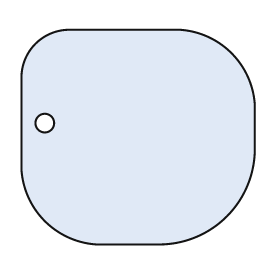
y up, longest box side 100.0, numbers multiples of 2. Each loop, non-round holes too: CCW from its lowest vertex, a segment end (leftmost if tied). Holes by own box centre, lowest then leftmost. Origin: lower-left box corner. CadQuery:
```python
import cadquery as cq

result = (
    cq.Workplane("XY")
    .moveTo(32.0, 0.0)
    .lineTo(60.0, 0.0)
    .threePointArc((88.0, 12.0), (100.0, 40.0))
    .lineTo(100.0, 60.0)
    .threePointArc((90.0, 82.0), (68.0, 92.0))
    .lineTo(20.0, 92.0)
    .threePointArc((6.0, 86.0), (0.0, 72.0))
    .lineTo(0.0, 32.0)
    .threePointArc((10.0, 10.0), (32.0, 0.0))
    .close()
    .moveTo(10.0, 52.0)
    .circle(4.0)
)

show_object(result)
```